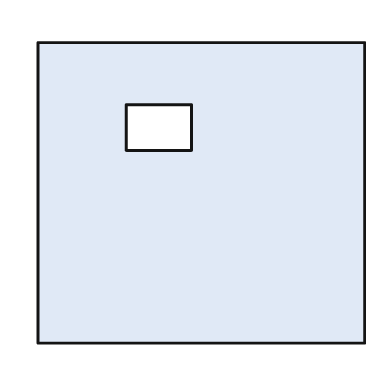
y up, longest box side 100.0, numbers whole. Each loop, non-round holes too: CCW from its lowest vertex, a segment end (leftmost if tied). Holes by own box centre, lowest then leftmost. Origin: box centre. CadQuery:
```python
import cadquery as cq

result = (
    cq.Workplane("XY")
    .moveTo(-50.0, -46.0)
    .lineTo(50.0, -46.0)
    .lineTo(50.0, 46.0)
    .lineTo(-50.0, 46.0)
    .close()
    .moveTo(-23.0, 13.0)
    .lineTo(-3.0, 13.0)
    .lineTo(-3.0, 27.0)
    .lineTo(-23.0, 27.0)
    .close()
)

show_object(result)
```